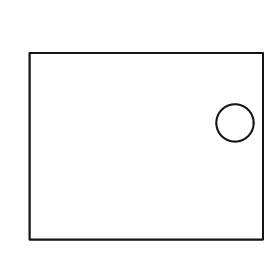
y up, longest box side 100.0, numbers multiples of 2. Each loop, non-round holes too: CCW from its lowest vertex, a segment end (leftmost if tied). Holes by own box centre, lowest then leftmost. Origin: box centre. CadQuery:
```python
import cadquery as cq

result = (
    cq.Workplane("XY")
    .moveTo(-50.0, -40.0)
    .lineTo(50.0, -40.0)
    .lineTo(50.0, 40.0)
    .lineTo(-50.0, 40.0)
    .close()
    .moveTo(38.0, 10.0)
    .circle(8.0)
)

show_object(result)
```